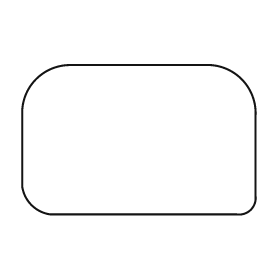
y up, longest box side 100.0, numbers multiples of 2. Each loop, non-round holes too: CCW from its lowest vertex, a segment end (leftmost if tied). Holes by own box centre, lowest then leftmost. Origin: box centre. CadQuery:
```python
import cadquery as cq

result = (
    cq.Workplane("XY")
    .moveTo(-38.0, -32.0)
    .lineTo(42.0, -32.0)
    .threePointArc((48.0, -30.0), (50.0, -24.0))
    .lineTo(50.0, 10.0)
    .threePointArc((44.0, 26.0), (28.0, 32.0))
    .lineTo(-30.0, 32.0)
    .threePointArc((-44.0, 26.0), (-50.0, 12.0))
    .lineTo(-50.0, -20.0)
    .threePointArc((-46.0, -28.0), (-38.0, -32.0))
    .close()
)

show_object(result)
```